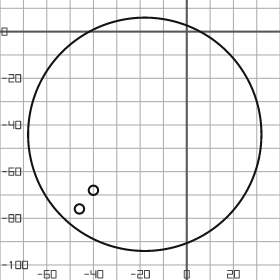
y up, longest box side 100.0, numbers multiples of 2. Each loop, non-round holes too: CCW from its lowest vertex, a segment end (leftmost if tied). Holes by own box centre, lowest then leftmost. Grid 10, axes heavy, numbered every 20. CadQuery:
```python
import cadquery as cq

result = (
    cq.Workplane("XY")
    .moveTo(-18.0, -44.0)
    .circle(50.0)
    .moveTo(-46.0, -76.0)
    .circle(2.0)
    .moveTo(-40.0, -68.0)
    .circle(2.0)
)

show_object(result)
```